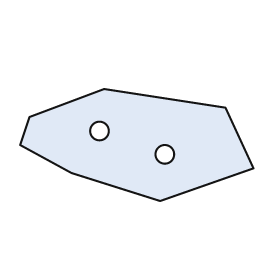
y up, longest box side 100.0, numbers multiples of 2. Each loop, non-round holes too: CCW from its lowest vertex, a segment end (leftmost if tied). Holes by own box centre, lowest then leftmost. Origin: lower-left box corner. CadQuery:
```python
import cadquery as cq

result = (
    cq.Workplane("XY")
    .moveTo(60.0, 0.0)
    .lineTo(100.0, 14.0)
    .lineTo(88.0, 40.0)
    .lineTo(36.0, 48.0)
    .lineTo(4.0, 36.0)
    .lineTo(0.0, 24.0)
    .lineTo(22.0, 12.0)
    .close()
    .moveTo(62.0, 20.0)
    .circle(4.0)
    .moveTo(34.0, 30.0)
    .circle(4.0)
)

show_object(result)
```